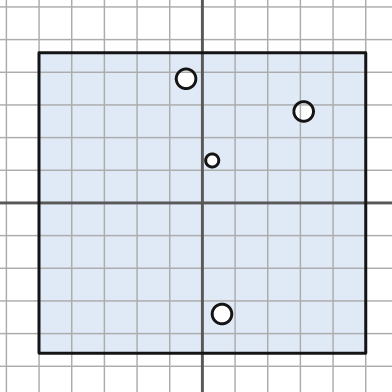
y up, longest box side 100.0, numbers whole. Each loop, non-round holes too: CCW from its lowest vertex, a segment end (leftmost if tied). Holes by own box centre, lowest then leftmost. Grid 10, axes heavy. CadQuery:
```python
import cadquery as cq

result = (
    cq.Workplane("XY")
    .moveTo(-50.0, -46.0)
    .lineTo(50.0, -46.0)
    .lineTo(50.0, 46.0)
    .lineTo(-50.0, 46.0)
    .close()
    .moveTo(6.0, -34.0)
    .circle(3.0)
    .moveTo(3.0, 13.0)
    .circle(2.0)
    .moveTo(31.0, 28.0)
    .circle(3.0)
    .moveTo(-5.0, 38.0)
    .circle(3.0)
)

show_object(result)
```